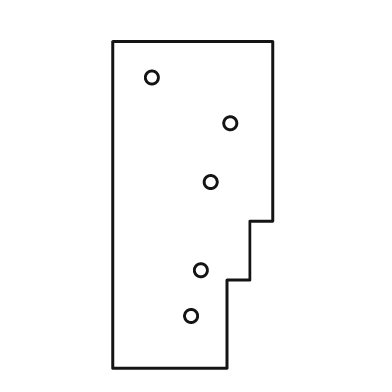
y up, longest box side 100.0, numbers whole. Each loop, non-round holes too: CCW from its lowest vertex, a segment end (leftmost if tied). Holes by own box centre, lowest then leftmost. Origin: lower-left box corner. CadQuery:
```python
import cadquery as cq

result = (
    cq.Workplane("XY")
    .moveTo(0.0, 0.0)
    .lineTo(35.0, 0.0)
    .lineTo(35.0, 27.0)
    .lineTo(42.0, 27.0)
    .lineTo(42.0, 45.0)
    .lineTo(49.0, 45.0)
    .lineTo(49.0, 100.0)
    .lineTo(0.0, 100.0)
    .close()
    .moveTo(24.0, 16.0)
    .circle(2.0)
    .moveTo(27.0, 30.0)
    .circle(2.0)
    .moveTo(30.0, 57.0)
    .circle(2.0)
    .moveTo(36.0, 75.0)
    .circle(2.0)
    .moveTo(12.0, 89.0)
    .circle(2.0)
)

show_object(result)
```